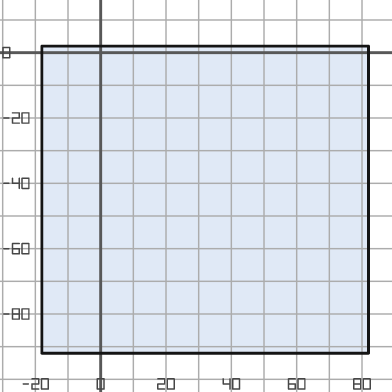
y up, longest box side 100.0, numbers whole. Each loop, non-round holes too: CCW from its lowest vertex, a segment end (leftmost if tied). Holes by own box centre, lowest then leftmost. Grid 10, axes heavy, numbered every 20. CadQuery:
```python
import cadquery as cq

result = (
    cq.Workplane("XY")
    .moveTo(-18.0, -92.0)
    .lineTo(82.0, -92.0)
    .lineTo(82.0, 2.0)
    .lineTo(-18.0, 2.0)
    .close()
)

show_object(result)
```